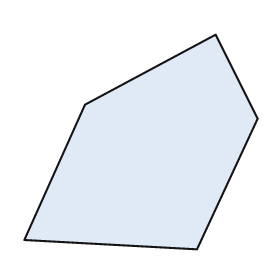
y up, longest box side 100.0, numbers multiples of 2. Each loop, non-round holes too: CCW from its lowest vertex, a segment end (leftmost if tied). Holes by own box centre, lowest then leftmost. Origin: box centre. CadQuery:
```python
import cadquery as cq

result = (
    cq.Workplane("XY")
    .moveTo(24.0, -46.0)
    .lineTo(50.0, 10.0)
    .lineTo(32.0, 46.0)
    .lineTo(-24.0, 16.0)
    .lineTo(-50.0, -42.0)
    .close()
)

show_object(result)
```